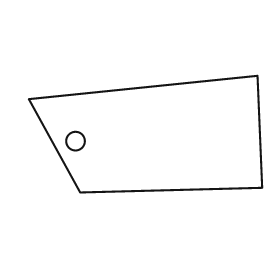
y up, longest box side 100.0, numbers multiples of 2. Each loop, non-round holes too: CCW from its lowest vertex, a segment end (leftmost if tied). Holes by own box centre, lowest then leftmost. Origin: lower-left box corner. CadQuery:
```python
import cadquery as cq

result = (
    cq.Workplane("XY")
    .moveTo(22.0, 0.0)
    .lineTo(100.0, 2.0)
    .lineTo(98.0, 50.0)
    .lineTo(0.0, 40.0)
    .close()
    .moveTo(20.0, 22.0)
    .circle(4.0)
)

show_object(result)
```